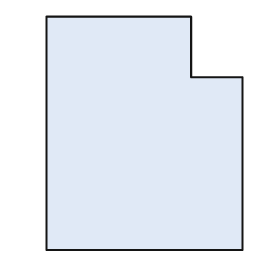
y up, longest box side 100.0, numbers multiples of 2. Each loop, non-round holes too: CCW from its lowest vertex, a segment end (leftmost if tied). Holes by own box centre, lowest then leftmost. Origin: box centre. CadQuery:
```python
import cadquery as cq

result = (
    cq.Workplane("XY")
    .moveTo(-42.0, -50.0)
    .lineTo(42.0, -50.0)
    .lineTo(42.0, 24.0)
    .lineTo(20.0, 24.0)
    .lineTo(20.0, 50.0)
    .lineTo(-42.0, 50.0)
    .close()
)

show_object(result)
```